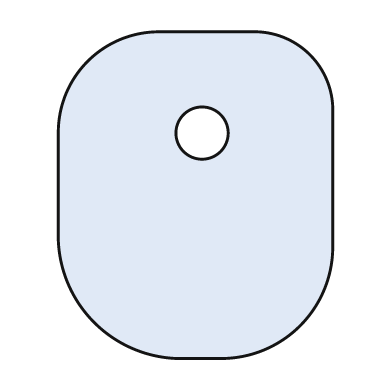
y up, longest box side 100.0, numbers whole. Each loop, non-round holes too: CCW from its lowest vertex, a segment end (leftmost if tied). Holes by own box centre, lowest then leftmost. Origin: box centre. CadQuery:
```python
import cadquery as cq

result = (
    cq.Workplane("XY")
    .moveTo(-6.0, -50.0)
    .lineTo(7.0, -50.0)
    .threePointArc((32.0, -40.0), (42.0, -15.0))
    .lineTo(42.0, 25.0)
    .threePointArc((35.0, 43.0), (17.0, 50.0))
    .lineTo(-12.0, 50.0)
    .threePointArc((-33.0, 41.0), (-42.0, 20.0))
    .lineTo(-42.0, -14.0)
    .threePointArc((-31.0, -39.0), (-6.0, -50.0))
    .close()
    .moveTo(2.0, 19.0)
    .circle(8.0)
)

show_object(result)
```